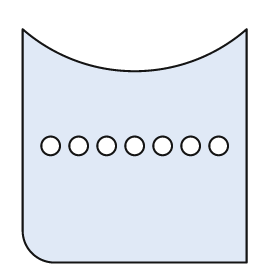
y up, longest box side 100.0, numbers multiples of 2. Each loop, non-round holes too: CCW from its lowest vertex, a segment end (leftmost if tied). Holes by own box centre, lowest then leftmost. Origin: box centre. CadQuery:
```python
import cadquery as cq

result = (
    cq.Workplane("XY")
    .moveTo(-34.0, -50.0)
    .lineTo(48.0, -50.0)
    .lineTo(48.0, 50.0)
    .threePointArc((0.0, 32.0), (-48.0, 50.0))
    .lineTo(-48.0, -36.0)
    .threePointArc((-44.0, -46.0), (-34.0, -50.0))
    .close()
    .moveTo(-36.0, 0.0)
    .circle(4.0)
    .moveTo(-24.0, 0.0)
    .circle(4.0)
    .moveTo(-12.0, 0.0)
    .circle(4.0)
    .moveTo(0.0, 0.0)
    .circle(4.0)
    .moveTo(12.0, 0.0)
    .circle(4.0)
    .moveTo(24.0, 0.0)
    .circle(4.0)
    .moveTo(36.0, 0.0)
    .circle(4.0)
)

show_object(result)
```